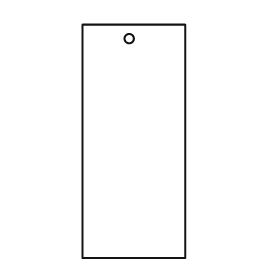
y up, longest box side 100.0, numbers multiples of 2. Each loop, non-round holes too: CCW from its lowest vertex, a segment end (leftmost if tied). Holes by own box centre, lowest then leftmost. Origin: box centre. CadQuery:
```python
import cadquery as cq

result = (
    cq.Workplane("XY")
    .moveTo(-22.0, -50.0)
    .lineTo(22.0, -50.0)
    .lineTo(22.0, 50.0)
    .lineTo(-22.0, 50.0)
    .close()
    .moveTo(-2.0, 44.0)
    .circle(2.0)
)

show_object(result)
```